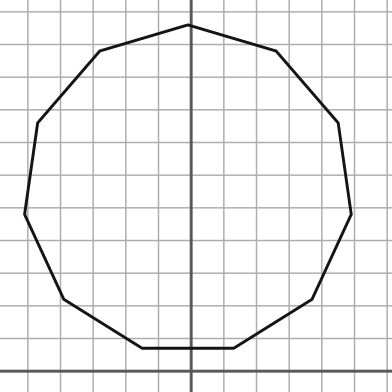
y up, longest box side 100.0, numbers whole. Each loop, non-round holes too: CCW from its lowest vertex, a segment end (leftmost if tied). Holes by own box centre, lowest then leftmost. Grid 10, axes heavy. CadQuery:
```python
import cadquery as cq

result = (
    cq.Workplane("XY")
    .moveTo(-15.0, 7.0)
    .lineTo(13.0, 7.0)
    .lineTo(37.0, 22.0)
    .lineTo(49.0, 48.0)
    .lineTo(45.0, 76.0)
    .lineTo(26.0, 98.0)
    .lineTo(-1.0, 106.0)
    .lineTo(-28.0, 98.0)
    .lineTo(-47.0, 76.0)
    .lineTo(-51.0, 48.0)
    .lineTo(-39.0, 22.0)
    .close()
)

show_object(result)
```